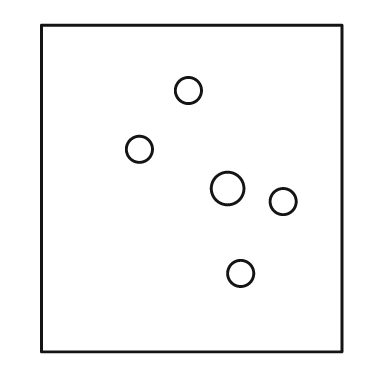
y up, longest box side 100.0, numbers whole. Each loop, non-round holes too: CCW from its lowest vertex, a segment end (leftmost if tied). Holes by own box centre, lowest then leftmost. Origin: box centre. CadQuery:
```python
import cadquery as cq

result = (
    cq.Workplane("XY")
    .moveTo(-46.0, -50.0)
    .lineTo(46.0, -50.0)
    .lineTo(46.0, 50.0)
    .lineTo(-46.0, 50.0)
    .close()
    .moveTo(15.0, -26.0)
    .circle(4.0)
    .moveTo(28.0, -4.0)
    .circle(4.0)
    .moveTo(11.0, 0.0)
    .circle(5.0)
    .moveTo(-16.0, 12.0)
    .circle(4.0)
    .moveTo(-1.0, 30.0)
    .circle(4.0)
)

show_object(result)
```